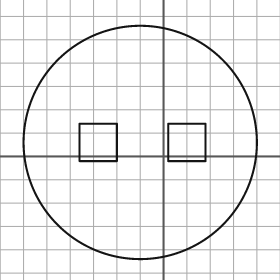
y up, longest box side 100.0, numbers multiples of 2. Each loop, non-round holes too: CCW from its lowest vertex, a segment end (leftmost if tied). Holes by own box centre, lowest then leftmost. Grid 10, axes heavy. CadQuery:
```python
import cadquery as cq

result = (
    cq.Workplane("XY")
    .moveTo(-10.0, 6.0)
    .circle(50.0)
    .moveTo(-36.0, -2.0)
    .lineTo(-20.0, -2.0)
    .lineTo(-20.0, 14.0)
    .lineTo(-36.0, 14.0)
    .close()
    .moveTo(2.0, -2.0)
    .lineTo(18.0, -2.0)
    .lineTo(18.0, 14.0)
    .lineTo(2.0, 14.0)
    .close()
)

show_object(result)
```